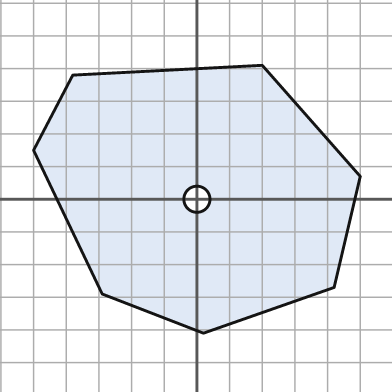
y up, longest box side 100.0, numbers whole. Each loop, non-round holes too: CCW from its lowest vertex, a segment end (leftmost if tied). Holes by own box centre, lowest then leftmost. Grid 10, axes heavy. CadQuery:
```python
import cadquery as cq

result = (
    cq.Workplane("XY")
    .moveTo(2.0, -41.0)
    .lineTo(42.0, -27.0)
    .lineTo(50.0, 7.0)
    .lineTo(20.0, 41.0)
    .lineTo(-38.0, 38.0)
    .lineTo(-50.0, 15.0)
    .lineTo(-29.0, -29.0)
    .close()
    .moveTo(0.0, 0.0)
    .circle(4.0)
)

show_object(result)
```